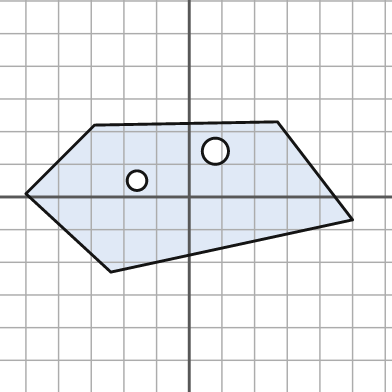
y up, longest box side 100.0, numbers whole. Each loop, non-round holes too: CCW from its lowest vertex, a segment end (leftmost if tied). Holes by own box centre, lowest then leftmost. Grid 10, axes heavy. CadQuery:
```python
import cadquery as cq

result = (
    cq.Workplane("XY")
    .moveTo(-24.0, -23.0)
    .lineTo(50.0, -7.0)
    .lineTo(27.0, 23.0)
    .lineTo(-29.0, 22.0)
    .lineTo(-50.0, 1.0)
    .close()
    .moveTo(-16.0, 5.0)
    .circle(3.0)
    .moveTo(8.0, 14.0)
    .circle(4.0)
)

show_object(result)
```